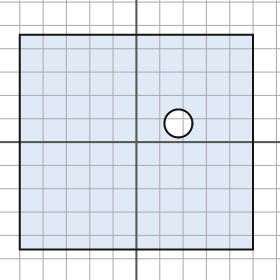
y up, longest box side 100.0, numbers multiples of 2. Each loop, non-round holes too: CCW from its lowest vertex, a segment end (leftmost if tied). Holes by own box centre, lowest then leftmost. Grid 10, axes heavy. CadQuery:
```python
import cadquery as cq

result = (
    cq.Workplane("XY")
    .moveTo(-50.0, -46.0)
    .lineTo(50.0, -46.0)
    .lineTo(50.0, 46.0)
    .lineTo(-50.0, 46.0)
    .close()
    .moveTo(18.0, 8.0)
    .circle(6.0)
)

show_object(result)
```